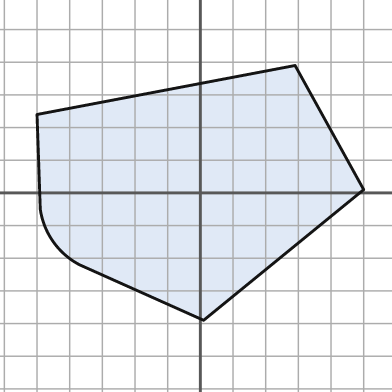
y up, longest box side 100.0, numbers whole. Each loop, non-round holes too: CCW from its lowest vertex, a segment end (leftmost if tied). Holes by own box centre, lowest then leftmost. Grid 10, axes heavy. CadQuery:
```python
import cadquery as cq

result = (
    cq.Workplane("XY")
    .moveTo(1.0, -39.0)
    .lineTo(50.0, 1.0)
    .lineTo(29.0, 39.0)
    .lineTo(-50.0, 24.0)
    .lineTo(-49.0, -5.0)
    .threePointArc((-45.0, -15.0), (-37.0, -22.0))
    .close()
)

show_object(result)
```